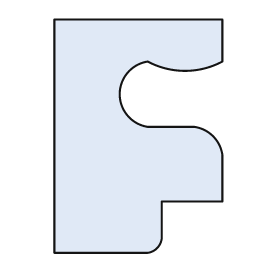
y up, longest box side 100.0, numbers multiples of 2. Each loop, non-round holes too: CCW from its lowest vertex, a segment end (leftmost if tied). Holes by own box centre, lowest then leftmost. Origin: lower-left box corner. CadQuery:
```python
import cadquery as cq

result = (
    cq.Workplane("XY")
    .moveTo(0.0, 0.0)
    .lineTo(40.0, 0.0)
    .threePointArc((44.0, 2.0), (46.0, 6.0))
    .lineTo(46.0, 22.0)
    .lineTo(72.0, 22.0)
    .lineTo(72.0, 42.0)
    .threePointArc((68.0, 50.0), (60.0, 54.0))
    .lineTo(40.0, 54.0)
    .threePointArc((28.0, 68.0), (40.0, 82.0))
    .threePointArc((56.0, 78.0), (72.0, 82.0))
    .lineTo(72.0, 100.0)
    .lineTo(0.0, 100.0)
    .close()
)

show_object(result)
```